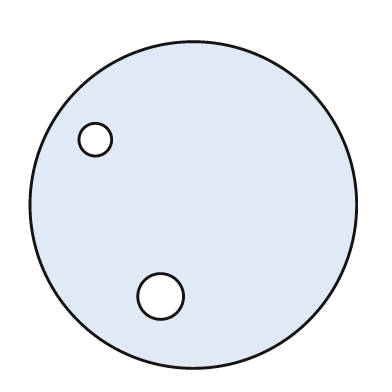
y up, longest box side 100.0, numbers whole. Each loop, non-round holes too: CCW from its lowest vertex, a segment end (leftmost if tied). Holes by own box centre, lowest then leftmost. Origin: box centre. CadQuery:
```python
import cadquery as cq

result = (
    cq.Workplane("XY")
    .moveTo(0.0, 0.0)
    .circle(50.0)
    .moveTo(-10.0, -28.0)
    .circle(7.0)
    .moveTo(-30.0, 20.0)
    .circle(5.0)
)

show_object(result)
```